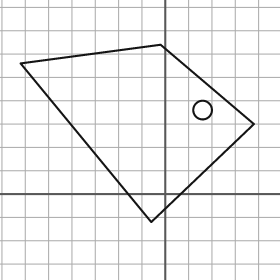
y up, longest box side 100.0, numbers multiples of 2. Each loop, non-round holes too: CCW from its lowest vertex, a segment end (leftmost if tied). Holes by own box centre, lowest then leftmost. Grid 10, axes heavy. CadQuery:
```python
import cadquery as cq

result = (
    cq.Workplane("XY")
    .moveTo(-6.0, -12.0)
    .lineTo(38.0, 30.0)
    .lineTo(-2.0, 64.0)
    .lineTo(-62.0, 56.0)
    .close()
    .moveTo(16.0, 36.0)
    .circle(4.0)
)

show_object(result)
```